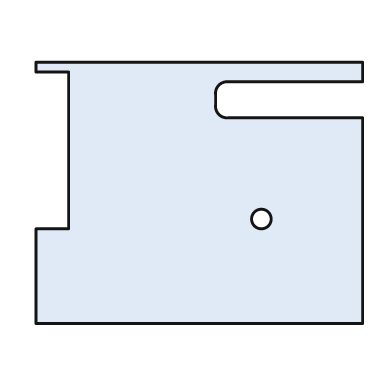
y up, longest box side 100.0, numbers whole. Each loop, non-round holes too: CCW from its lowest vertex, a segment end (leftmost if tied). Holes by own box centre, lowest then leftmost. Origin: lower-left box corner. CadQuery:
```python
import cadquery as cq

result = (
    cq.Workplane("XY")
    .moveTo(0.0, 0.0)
    .lineTo(100.0, 0.0)
    .lineTo(100.0, 63.0)
    .lineTo(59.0, 63.0)
    .threePointArc((56.0, 64.0), (55.0, 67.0))
    .lineTo(55.0, 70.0)
    .threePointArc((56.0, 73.0), (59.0, 74.0))
    .lineTo(100.0, 74.0)
    .lineTo(100.0, 80.0)
    .lineTo(0.0, 80.0)
    .lineTo(0.0, 77.0)
    .lineTo(10.0, 77.0)
    .lineTo(10.0, 29.0)
    .lineTo(0.0, 29.0)
    .close()
    .moveTo(69.0, 32.0)
    .circle(3.0)
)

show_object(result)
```